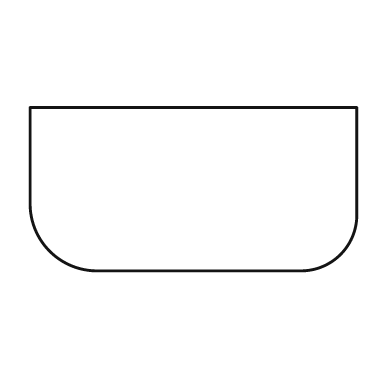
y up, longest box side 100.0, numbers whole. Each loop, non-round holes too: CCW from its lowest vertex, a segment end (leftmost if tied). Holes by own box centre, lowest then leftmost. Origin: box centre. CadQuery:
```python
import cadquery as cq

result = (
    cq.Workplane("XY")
    .moveTo(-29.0, -25.0)
    .lineTo(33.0, -25.0)
    .threePointArc((45.0, -20.0), (50.0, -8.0))
    .lineTo(50.0, 25.0)
    .lineTo(-50.0, 25.0)
    .lineTo(-50.0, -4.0)
    .threePointArc((-44.0, -19.0), (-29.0, -25.0))
    .close()
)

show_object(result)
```